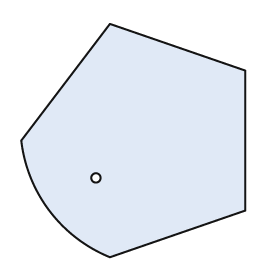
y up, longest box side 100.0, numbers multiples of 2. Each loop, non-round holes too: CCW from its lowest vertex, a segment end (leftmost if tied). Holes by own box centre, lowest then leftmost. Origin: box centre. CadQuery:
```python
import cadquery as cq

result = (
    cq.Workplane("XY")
    .moveTo(-10.0, -50.0)
    .lineTo(48.0, -30.0)
    .lineTo(48.0, 30.0)
    .lineTo(-10.0, 50.0)
    .lineTo(-48.0, 0.0)
    .threePointArc((-36.0, -30.0), (-10.0, -50.0))
    .close()
    .moveTo(-16.0, -16.0)
    .circle(2.0)
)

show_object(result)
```